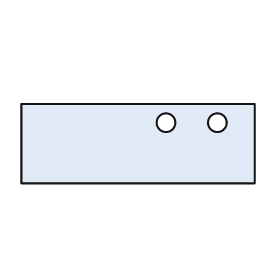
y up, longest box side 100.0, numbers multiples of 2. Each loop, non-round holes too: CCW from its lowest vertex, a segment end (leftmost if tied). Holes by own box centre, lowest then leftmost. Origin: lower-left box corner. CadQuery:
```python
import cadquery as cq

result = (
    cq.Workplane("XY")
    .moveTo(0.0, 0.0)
    .lineTo(100.0, 0.0)
    .lineTo(100.0, 34.0)
    .lineTo(0.0, 34.0)
    .close()
    .moveTo(62.0, 26.0)
    .circle(4.0)
    .moveTo(84.0, 26.0)
    .circle(4.0)
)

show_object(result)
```